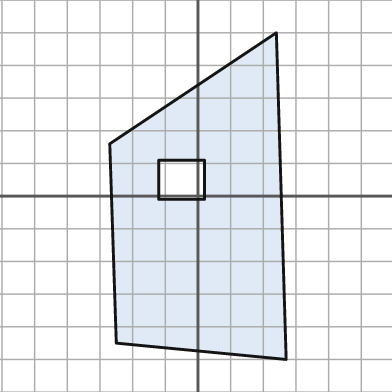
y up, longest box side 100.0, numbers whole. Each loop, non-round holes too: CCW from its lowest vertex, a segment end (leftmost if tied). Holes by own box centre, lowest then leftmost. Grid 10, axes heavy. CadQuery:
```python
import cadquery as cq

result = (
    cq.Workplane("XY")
    .moveTo(27.0, -50.0)
    .lineTo(24.0, 50.0)
    .lineTo(-27.0, 16.0)
    .lineTo(-25.0, -45.0)
    .close()
    .moveTo(-12.0, -1.0)
    .lineTo(2.0, -1.0)
    .lineTo(2.0, 11.0)
    .lineTo(-12.0, 11.0)
    .close()
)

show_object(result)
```